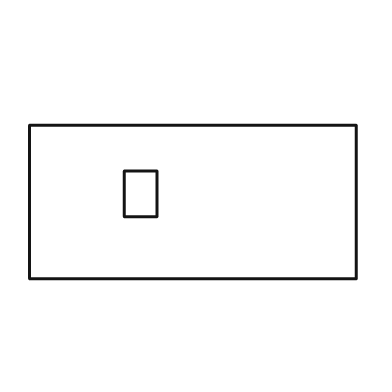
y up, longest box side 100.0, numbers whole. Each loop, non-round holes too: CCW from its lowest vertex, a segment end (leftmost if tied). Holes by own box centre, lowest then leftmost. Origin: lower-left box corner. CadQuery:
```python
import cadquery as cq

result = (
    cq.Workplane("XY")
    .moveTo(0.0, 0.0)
    .lineTo(100.0, 0.0)
    .lineTo(100.0, 47.0)
    .lineTo(0.0, 47.0)
    .close()
    .moveTo(29.0, 19.0)
    .lineTo(39.0, 19.0)
    .lineTo(39.0, 33.0)
    .lineTo(29.0, 33.0)
    .close()
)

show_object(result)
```